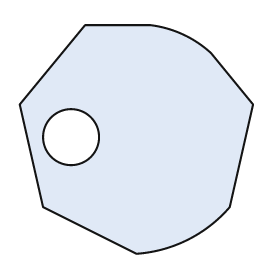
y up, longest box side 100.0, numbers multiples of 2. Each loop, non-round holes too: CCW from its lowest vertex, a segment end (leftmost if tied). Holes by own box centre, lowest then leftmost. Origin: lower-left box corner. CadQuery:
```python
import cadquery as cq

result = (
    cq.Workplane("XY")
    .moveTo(50.0, 0.0)
    .threePointArc((72.0, 6.0), (90.0, 20.0))
    .lineTo(100.0, 64.0)
    .lineTo(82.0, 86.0)
    .threePointArc((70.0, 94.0), (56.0, 98.0))
    .lineTo(28.0, 98.0)
    .lineTo(0.0, 64.0)
    .lineTo(10.0, 20.0)
    .close()
    .moveTo(22.0, 50.0)
    .circle(12.0)
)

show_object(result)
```